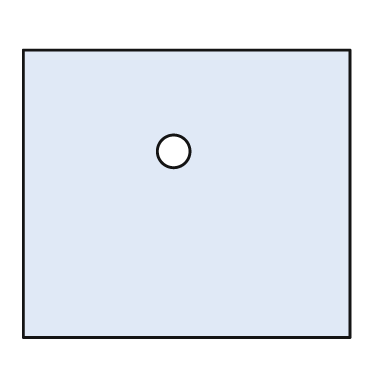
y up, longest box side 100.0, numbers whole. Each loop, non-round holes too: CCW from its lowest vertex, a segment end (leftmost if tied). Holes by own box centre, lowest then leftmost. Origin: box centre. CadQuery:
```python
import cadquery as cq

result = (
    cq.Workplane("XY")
    .moveTo(-50.0, -44.0)
    .lineTo(50.0, -44.0)
    .lineTo(50.0, 44.0)
    .lineTo(-50.0, 44.0)
    .close()
    .moveTo(-4.0, 13.0)
    .circle(5.0)
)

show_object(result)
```